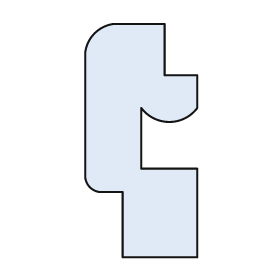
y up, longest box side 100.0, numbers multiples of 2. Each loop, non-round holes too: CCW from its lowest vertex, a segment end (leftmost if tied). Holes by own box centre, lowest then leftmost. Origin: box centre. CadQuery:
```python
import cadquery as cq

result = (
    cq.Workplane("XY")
    .moveTo(-8.0, -50.0)
    .lineTo(24.0, -50.0)
    .lineTo(24.0, -12.0)
    .lineTo(0.0, -12.0)
    .lineTo(0.0, 14.0)
    .threePointArc((12.0, 8.0), (24.0, 14.0))
    .lineTo(24.0, 28.0)
    .lineTo(10.0, 28.0)
    .lineTo(10.0, 50.0)
    .lineTo(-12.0, 50.0)
    .threePointArc((-20.0, 46.0), (-24.0, 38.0))
    .lineTo(-24.0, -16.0)
    .threePointArc((-22.0, -20.0), (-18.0, -22.0))
    .lineTo(-8.0, -22.0)
    .close()
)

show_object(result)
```